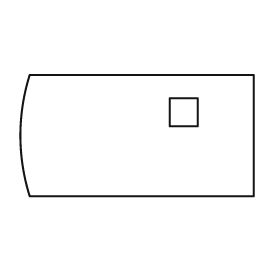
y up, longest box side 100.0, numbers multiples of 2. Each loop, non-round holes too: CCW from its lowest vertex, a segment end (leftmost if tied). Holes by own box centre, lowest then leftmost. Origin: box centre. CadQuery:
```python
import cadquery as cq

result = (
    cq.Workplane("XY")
    .moveTo(-46.0, -26.0)
    .lineTo(50.0, -26.0)
    .lineTo(50.0, 26.0)
    .lineTo(-46.0, 26.0)
    .threePointArc((-50.0, 0.0), (-46.0, -26.0))
    .close()
    .moveTo(14.0, 4.0)
    .lineTo(26.0, 4.0)
    .lineTo(26.0, 16.0)
    .lineTo(14.0, 16.0)
    .close()
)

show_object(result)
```